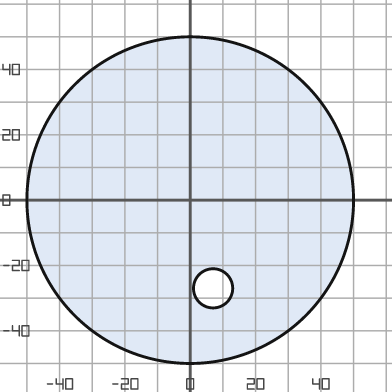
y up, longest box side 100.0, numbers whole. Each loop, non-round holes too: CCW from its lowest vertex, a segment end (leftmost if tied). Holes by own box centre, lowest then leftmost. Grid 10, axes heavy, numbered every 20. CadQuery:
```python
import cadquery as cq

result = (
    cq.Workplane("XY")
    .moveTo(0.0, 0.0)
    .circle(50.0)
    .moveTo(7.0, -27.0)
    .circle(6.0)
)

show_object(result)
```